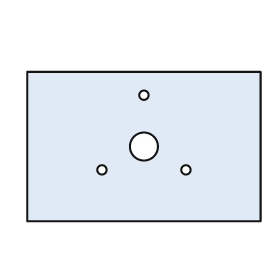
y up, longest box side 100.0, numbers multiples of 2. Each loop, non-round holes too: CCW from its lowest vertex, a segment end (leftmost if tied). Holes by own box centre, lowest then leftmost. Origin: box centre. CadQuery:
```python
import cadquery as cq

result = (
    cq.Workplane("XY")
    .moveTo(-50.0, -32.0)
    .lineTo(50.0, -32.0)
    .lineTo(50.0, 32.0)
    .lineTo(-50.0, 32.0)
    .close()
    .moveTo(-18.0, -10.0)
    .circle(2.0)
    .moveTo(18.0, -10.0)
    .circle(2.0)
    .moveTo(0.0, 0.0)
    .circle(6.0)
    .moveTo(0.0, 22.0)
    .circle(2.0)
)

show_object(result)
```